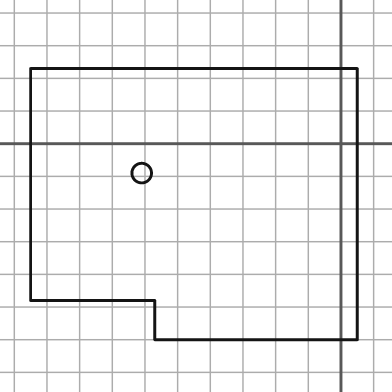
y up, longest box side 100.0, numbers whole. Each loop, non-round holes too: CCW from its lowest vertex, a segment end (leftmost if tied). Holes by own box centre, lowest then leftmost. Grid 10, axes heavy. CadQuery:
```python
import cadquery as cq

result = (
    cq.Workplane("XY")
    .moveTo(-57.0, -60.0)
    .lineTo(5.0, -60.0)
    .lineTo(5.0, 23.0)
    .lineTo(-95.0, 23.0)
    .lineTo(-95.0, -48.0)
    .lineTo(-57.0, -48.0)
    .close()
    .moveTo(-61.0, -9.0)
    .circle(3.0)
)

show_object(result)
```